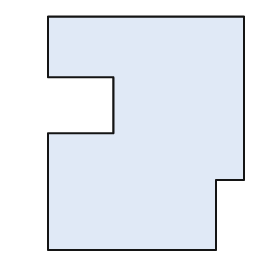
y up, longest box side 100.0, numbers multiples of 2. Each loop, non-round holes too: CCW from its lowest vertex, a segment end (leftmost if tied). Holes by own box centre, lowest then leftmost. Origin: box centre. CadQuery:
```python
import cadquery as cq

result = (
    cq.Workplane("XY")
    .moveTo(-42.0, -50.0)
    .lineTo(30.0, -50.0)
    .lineTo(30.0, -20.0)
    .lineTo(42.0, -20.0)
    .lineTo(42.0, 50.0)
    .lineTo(-42.0, 50.0)
    .lineTo(-42.0, 24.0)
    .lineTo(-14.0, 24.0)
    .lineTo(-14.0, 0.0)
    .lineTo(-42.0, 0.0)
    .close()
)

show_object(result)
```